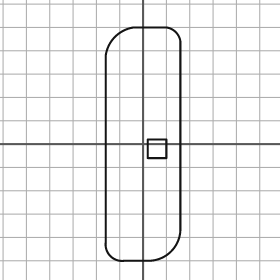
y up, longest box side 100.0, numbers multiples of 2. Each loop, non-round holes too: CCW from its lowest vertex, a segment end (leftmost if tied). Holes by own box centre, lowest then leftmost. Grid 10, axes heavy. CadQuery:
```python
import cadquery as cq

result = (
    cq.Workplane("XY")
    .moveTo(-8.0, -50.0)
    .lineTo(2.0, -50.0)
    .threePointArc((12.0, -46.0), (16.0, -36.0))
    .lineTo(16.0, 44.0)
    .threePointArc((14.0, 48.0), (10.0, 50.0))
    .lineTo(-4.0, 50.0)
    .threePointArc((-12.0, 46.0), (-16.0, 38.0))
    .lineTo(-16.0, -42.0)
    .threePointArc((-14.0, -48.0), (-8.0, -50.0))
    .close()
    .moveTo(2.0, -6.0)
    .lineTo(10.0, -6.0)
    .lineTo(10.0, 2.0)
    .lineTo(2.0, 2.0)
    .close()
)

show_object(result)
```